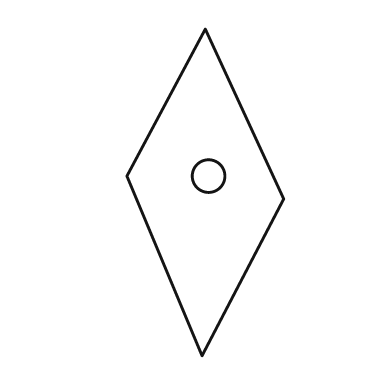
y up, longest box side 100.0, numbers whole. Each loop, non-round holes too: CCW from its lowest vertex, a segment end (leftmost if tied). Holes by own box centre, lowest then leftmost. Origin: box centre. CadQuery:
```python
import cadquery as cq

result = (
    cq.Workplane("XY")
    .moveTo(-1.0, -50.0)
    .lineTo(24.0, -2.0)
    .lineTo(0.0, 50.0)
    .lineTo(-24.0, 5.0)
    .close()
    .moveTo(1.0, 5.0)
    .circle(5.0)
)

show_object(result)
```